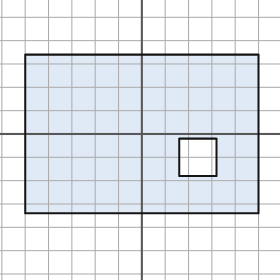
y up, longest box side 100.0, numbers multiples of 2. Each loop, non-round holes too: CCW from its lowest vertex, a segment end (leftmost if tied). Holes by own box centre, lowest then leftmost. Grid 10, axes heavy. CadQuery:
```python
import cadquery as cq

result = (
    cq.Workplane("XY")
    .moveTo(-50.0, -34.0)
    .lineTo(50.0, -34.0)
    .lineTo(50.0, 34.0)
    .lineTo(-50.0, 34.0)
    .close()
    .moveTo(16.0, -18.0)
    .lineTo(32.0, -18.0)
    .lineTo(32.0, -2.0)
    .lineTo(16.0, -2.0)
    .close()
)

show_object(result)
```